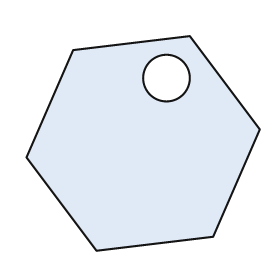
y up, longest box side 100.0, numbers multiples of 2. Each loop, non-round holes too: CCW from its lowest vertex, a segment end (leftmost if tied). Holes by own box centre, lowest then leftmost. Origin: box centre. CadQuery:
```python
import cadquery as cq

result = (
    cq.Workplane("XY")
    .moveTo(-20.0, -46.0)
    .lineTo(30.0, -40.0)
    .lineTo(50.0, 6.0)
    .lineTo(20.0, 46.0)
    .lineTo(-30.0, 40.0)
    .lineTo(-50.0, -6.0)
    .close()
    .moveTo(10.0, 28.0)
    .circle(10.0)
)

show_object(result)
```